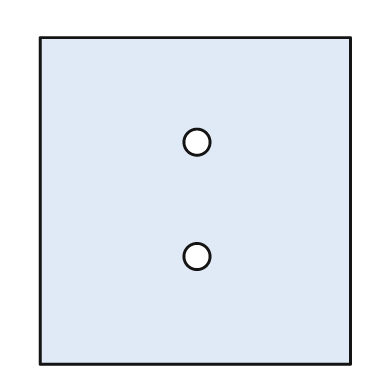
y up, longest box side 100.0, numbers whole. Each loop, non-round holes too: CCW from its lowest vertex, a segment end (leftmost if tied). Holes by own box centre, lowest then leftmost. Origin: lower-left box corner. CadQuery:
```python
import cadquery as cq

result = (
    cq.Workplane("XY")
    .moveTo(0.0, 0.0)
    .lineTo(95.0, 0.0)
    .lineTo(95.0, 100.0)
    .lineTo(0.0, 100.0)
    .close()
    .moveTo(48.0, 33.0)
    .circle(4.0)
    .moveTo(48.0, 68.0)
    .circle(4.0)
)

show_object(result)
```